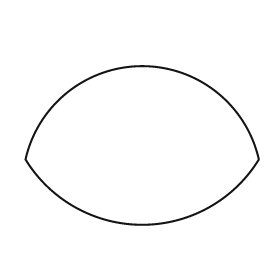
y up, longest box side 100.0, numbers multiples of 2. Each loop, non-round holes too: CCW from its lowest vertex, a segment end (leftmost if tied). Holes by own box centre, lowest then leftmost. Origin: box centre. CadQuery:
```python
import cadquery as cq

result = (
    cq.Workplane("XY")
    .moveTo(-50.0, -6.0)
    .threePointArc((0.0, -34.0), (50.0, -6.0))
    .threePointArc((0.0, 34.0), (-50.0, -6.0))
    .close()
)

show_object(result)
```